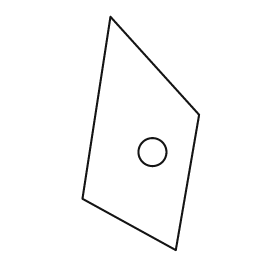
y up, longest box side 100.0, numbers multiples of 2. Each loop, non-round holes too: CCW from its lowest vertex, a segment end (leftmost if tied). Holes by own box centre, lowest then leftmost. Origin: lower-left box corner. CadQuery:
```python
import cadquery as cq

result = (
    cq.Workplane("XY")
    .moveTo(40.0, 0.0)
    .lineTo(50.0, 58.0)
    .lineTo(12.0, 100.0)
    .lineTo(0.0, 22.0)
    .close()
    .moveTo(30.0, 42.0)
    .circle(6.0)
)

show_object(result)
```